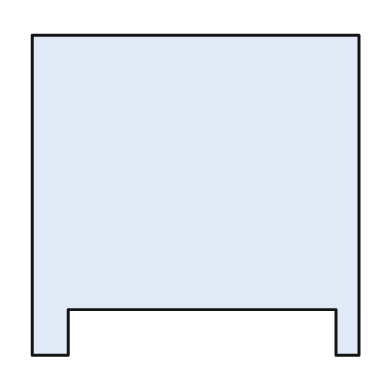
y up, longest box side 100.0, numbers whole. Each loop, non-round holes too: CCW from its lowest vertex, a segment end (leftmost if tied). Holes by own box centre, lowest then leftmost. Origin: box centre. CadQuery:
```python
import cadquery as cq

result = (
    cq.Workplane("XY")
    .moveTo(-50.0, -49.0)
    .lineTo(-39.0, -49.0)
    .lineTo(-39.0, -35.0)
    .lineTo(43.0, -35.0)
    .lineTo(43.0, -49.0)
    .lineTo(50.0, -49.0)
    .lineTo(50.0, 49.0)
    .lineTo(-50.0, 49.0)
    .close()
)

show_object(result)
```